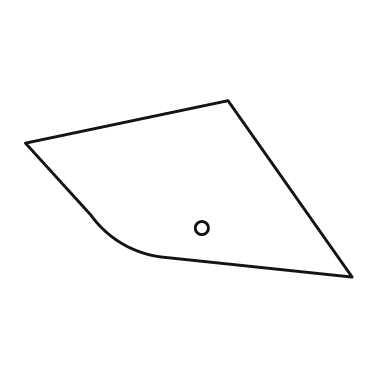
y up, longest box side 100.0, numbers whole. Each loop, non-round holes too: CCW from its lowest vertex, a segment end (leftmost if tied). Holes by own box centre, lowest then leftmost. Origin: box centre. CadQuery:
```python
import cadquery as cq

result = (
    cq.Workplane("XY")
    .moveTo(50.0, -27.0)
    .lineTo(12.0, 27.0)
    .lineTo(-50.0, 14.0)
    .lineTo(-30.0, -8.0)
    .threePointArc((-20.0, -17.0), (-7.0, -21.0))
    .close()
    .moveTo(4.0, -12.0)
    .circle(2.0)
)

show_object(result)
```